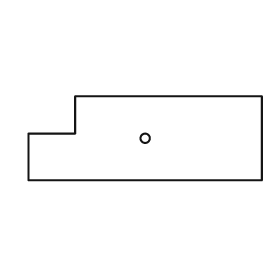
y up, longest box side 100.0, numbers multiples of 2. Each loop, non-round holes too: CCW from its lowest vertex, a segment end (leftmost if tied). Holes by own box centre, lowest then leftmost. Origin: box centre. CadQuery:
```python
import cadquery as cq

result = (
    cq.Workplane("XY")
    .moveTo(-50.0, -18.0)
    .lineTo(50.0, -18.0)
    .lineTo(50.0, 18.0)
    .lineTo(-30.0, 18.0)
    .lineTo(-30.0, 2.0)
    .lineTo(-50.0, 2.0)
    .close()
    .moveTo(0.0, 0.0)
    .circle(2.0)
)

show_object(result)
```